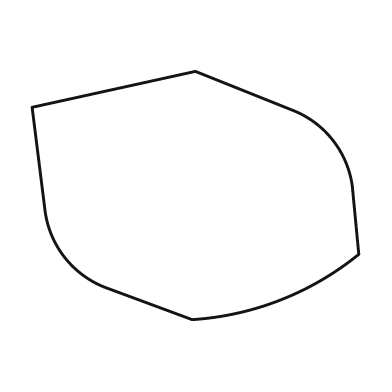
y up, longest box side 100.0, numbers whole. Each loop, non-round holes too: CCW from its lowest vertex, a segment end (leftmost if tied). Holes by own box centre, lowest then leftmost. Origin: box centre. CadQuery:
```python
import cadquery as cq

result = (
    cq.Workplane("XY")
    .moveTo(-1.0, -38.0)
    .threePointArc((26.0, -32.0), (50.0, -18.0))
    .lineTo(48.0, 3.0)
    .threePointArc((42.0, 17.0), (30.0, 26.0))
    .lineTo(0.0, 38.0)
    .lineTo(-50.0, 27.0)
    .lineTo(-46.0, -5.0)
    .threePointArc((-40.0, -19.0), (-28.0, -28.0))
    .close()
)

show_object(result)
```